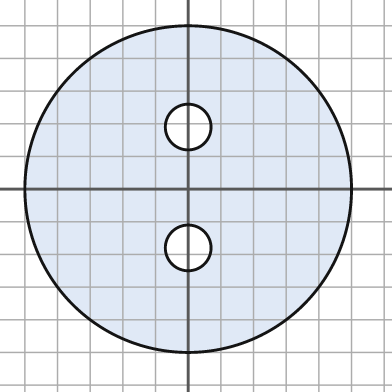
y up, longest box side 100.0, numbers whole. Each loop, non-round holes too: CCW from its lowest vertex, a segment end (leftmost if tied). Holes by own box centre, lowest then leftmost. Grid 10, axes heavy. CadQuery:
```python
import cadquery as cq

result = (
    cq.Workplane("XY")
    .moveTo(0.0, 0.0)
    .circle(50.0)
    .moveTo(0.0, -18.0)
    .circle(7.0)
    .moveTo(0.0, 19.0)
    .circle(7.0)
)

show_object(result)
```